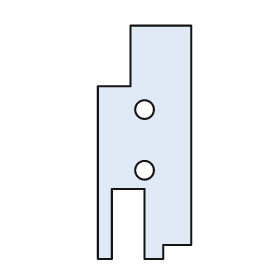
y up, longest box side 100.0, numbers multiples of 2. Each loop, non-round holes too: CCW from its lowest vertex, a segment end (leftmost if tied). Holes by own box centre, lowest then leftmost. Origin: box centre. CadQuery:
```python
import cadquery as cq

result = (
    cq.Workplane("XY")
    .moveTo(-20.0, -50.0)
    .lineTo(-14.0, -50.0)
    .lineTo(-14.0, -20.0)
    .lineTo(0.0, -20.0)
    .lineTo(0.0, -50.0)
    .lineTo(8.0, -50.0)
    .lineTo(8.0, -44.0)
    .lineTo(20.0, -44.0)
    .lineTo(20.0, 50.0)
    .lineTo(-6.0, 50.0)
    .lineTo(-6.0, 24.0)
    .lineTo(-20.0, 24.0)
    .close()
    .moveTo(0.0, -12.0)
    .circle(4.0)
    .moveTo(0.0, 14.0)
    .circle(4.0)
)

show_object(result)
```